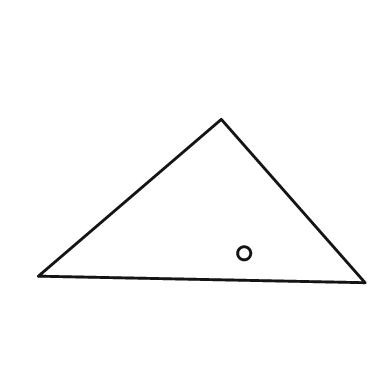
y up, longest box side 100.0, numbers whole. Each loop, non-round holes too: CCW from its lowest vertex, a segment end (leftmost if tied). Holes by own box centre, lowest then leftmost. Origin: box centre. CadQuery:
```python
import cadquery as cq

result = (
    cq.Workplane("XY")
    .moveTo(50.0, -25.0)
    .lineTo(6.0, 25.0)
    .lineTo(-50.0, -23.0)
    .close()
    .moveTo(13.0, -16.0)
    .circle(2.0)
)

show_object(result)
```